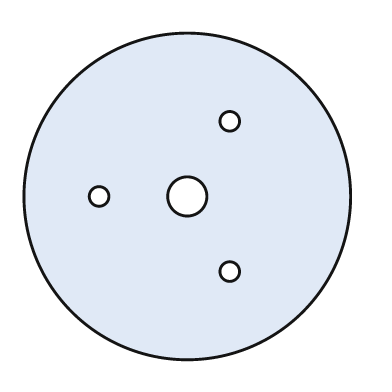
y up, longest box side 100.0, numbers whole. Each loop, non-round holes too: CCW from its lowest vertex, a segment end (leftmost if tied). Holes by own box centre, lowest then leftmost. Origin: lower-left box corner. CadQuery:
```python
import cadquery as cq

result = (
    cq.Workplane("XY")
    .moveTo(50.0, 50.0)
    .circle(50.0)
    .moveTo(63.0, 27.0)
    .circle(3.0)
    .moveTo(23.0, 50.0)
    .circle(3.0)
    .moveTo(50.0, 50.0)
    .circle(6.0)
    .moveTo(63.0, 73.0)
    .circle(3.0)
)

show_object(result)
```